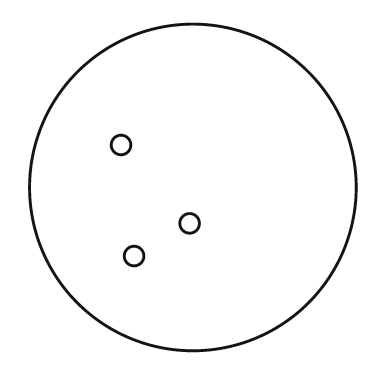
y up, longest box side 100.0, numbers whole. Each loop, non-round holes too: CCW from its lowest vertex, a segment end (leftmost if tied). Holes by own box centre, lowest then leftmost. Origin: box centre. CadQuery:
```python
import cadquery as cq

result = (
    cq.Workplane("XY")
    .moveTo(0.0, 0.0)
    .circle(50.0)
    .moveTo(-18.0, -21.0)
    .circle(3.0)
    .moveTo(-1.0, -11.0)
    .circle(3.0)
    .moveTo(-22.0, 13.0)
    .circle(3.0)
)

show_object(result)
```